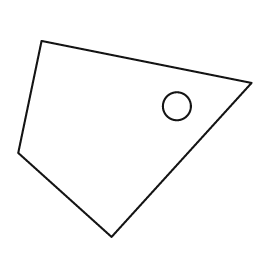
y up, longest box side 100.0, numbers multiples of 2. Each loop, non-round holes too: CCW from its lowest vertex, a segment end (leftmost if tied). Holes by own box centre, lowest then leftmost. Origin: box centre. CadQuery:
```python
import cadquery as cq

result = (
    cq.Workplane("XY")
    .moveTo(-10.0, -42.0)
    .lineTo(50.0, 24.0)
    .lineTo(-40.0, 42.0)
    .lineTo(-50.0, -6.0)
    .close()
    .moveTo(18.0, 14.0)
    .circle(6.0)
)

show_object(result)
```